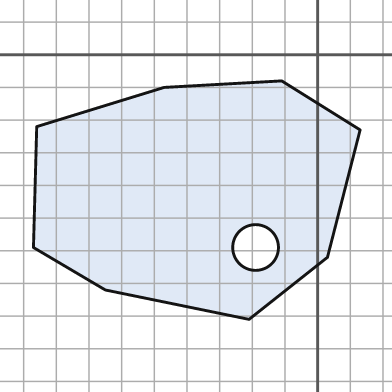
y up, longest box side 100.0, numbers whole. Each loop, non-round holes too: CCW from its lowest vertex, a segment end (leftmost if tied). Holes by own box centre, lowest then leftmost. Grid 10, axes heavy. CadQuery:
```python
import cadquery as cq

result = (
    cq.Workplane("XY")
    .moveTo(-21.0, -81.0)
    .lineTo(3.0, -62.0)
    .lineTo(13.0, -23.0)
    .lineTo(-11.0, -8.0)
    .lineTo(-47.0, -10.0)
    .lineTo(-86.0, -22.0)
    .lineTo(-87.0, -59.0)
    .lineTo(-65.0, -72.0)
    .close()
    .moveTo(-19.0, -59.0)
    .circle(7.0)
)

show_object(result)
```